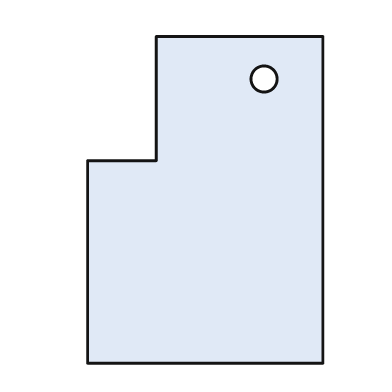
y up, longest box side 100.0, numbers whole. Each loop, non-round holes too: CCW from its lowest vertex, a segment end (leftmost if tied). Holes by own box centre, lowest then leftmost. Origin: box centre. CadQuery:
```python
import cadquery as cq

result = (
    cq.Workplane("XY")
    .moveTo(-36.0, -50.0)
    .lineTo(36.0, -50.0)
    .lineTo(36.0, 50.0)
    .lineTo(-15.0, 50.0)
    .lineTo(-15.0, 12.0)
    .lineTo(-36.0, 12.0)
    .close()
    .moveTo(18.0, 37.0)
    .circle(4.0)
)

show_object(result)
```